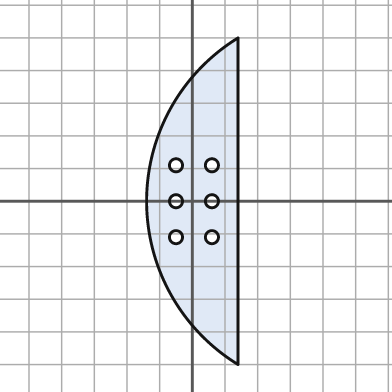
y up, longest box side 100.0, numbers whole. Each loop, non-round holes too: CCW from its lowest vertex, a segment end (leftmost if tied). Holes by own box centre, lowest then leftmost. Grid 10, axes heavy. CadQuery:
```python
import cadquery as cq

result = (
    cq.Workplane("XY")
    .moveTo(14.0, -50.0)
    .lineTo(14.0, 50.0)
    .threePointArc((-14.0, 0.0), (14.0, -50.0))
    .close()
    .moveTo(-5.0, -11.0)
    .circle(2.0)
    .moveTo(6.0, -11.0)
    .circle(2.0)
    .moveTo(-5.0, 0.0)
    .circle(2.0)
    .moveTo(6.0, 0.0)
    .circle(2.0)
    .moveTo(-5.0, 11.0)
    .circle(2.0)
    .moveTo(6.0, 11.0)
    .circle(2.0)
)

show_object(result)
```